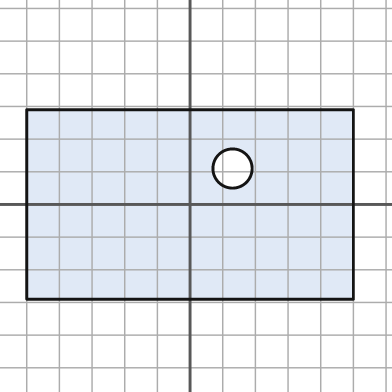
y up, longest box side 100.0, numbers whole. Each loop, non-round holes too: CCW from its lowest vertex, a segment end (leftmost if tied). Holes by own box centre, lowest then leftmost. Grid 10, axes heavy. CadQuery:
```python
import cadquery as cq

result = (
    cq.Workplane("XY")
    .moveTo(-50.0, -29.0)
    .lineTo(50.0, -29.0)
    .lineTo(50.0, 29.0)
    .lineTo(-50.0, 29.0)
    .close()
    .moveTo(13.0, 11.0)
    .circle(6.0)
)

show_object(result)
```